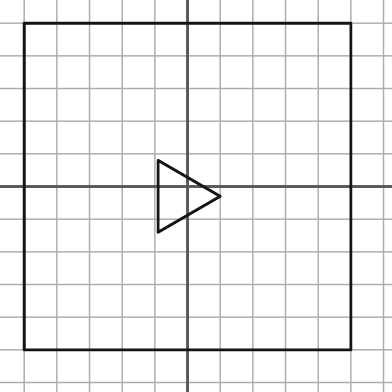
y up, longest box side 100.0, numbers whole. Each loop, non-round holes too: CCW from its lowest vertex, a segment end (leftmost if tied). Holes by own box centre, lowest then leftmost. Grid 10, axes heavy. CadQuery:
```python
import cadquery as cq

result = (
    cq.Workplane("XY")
    .moveTo(-50.0, -50.0)
    .lineTo(50.0, -50.0)
    .lineTo(50.0, 50.0)
    .lineTo(-50.0, 50.0)
    .close()
    .moveTo(-9.0, -14.0)
    .lineTo(10.0, -3.0)
    .lineTo(-9.0, 8.0)
    .close()
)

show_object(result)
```